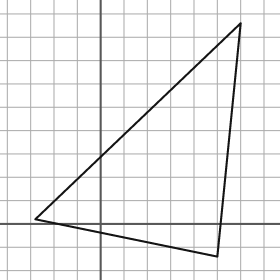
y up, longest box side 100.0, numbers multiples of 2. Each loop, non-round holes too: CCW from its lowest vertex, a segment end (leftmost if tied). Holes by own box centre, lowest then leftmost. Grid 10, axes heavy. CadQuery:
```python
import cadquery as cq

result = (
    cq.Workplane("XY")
    .moveTo(50.0, -14.0)
    .lineTo(60.0, 86.0)
    .lineTo(-28.0, 2.0)
    .close()
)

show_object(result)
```